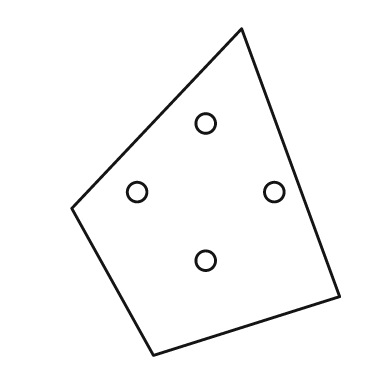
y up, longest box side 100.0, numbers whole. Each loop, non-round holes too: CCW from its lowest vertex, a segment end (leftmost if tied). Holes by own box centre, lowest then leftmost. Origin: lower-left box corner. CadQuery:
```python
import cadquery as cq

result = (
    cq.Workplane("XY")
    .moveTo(25.0, 0.0)
    .lineTo(82.0, 18.0)
    .lineTo(52.0, 100.0)
    .lineTo(0.0, 45.0)
    .close()
    .moveTo(41.0, 29.0)
    .circle(3.0)
    .moveTo(20.0, 50.0)
    .circle(3.0)
    .moveTo(62.0, 50.0)
    .circle(3.0)
    .moveTo(41.0, 71.0)
    .circle(3.0)
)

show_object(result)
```